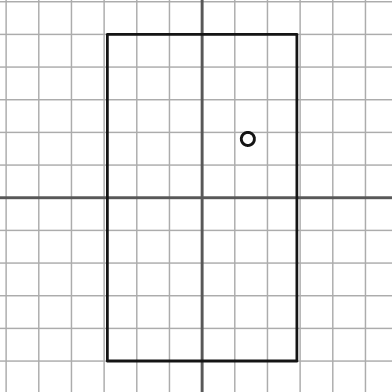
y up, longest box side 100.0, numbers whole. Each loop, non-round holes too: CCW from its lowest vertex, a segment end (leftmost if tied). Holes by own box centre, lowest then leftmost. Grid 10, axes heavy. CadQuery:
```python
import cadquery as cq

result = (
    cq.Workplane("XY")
    .moveTo(-29.0, -50.0)
    .lineTo(29.0, -50.0)
    .lineTo(29.0, 50.0)
    .lineTo(-29.0, 50.0)
    .close()
    .moveTo(14.0, 18.0)
    .circle(2.0)
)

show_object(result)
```